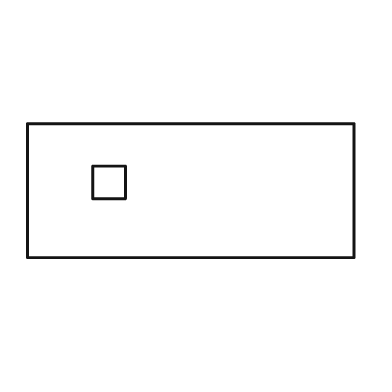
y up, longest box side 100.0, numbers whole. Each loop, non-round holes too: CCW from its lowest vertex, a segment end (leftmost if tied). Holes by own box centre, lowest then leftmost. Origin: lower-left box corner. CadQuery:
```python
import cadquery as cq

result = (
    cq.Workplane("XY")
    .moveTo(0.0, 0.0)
    .lineTo(100.0, 0.0)
    .lineTo(100.0, 41.0)
    .lineTo(0.0, 41.0)
    .close()
    .moveTo(20.0, 18.0)
    .lineTo(30.0, 18.0)
    .lineTo(30.0, 28.0)
    .lineTo(20.0, 28.0)
    .close()
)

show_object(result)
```